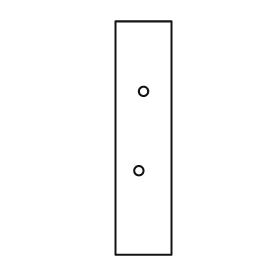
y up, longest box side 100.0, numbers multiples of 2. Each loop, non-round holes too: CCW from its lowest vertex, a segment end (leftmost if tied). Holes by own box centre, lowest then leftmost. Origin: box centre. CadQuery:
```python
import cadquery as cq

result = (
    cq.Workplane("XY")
    .moveTo(-12.0, -50.0)
    .lineTo(12.0, -50.0)
    .lineTo(12.0, 50.0)
    .lineTo(-12.0, 50.0)
    .close()
    .moveTo(-2.0, -14.0)
    .circle(2.0)
    .moveTo(0.0, 20.0)
    .circle(2.0)
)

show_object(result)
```